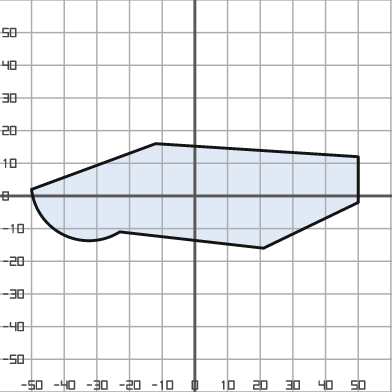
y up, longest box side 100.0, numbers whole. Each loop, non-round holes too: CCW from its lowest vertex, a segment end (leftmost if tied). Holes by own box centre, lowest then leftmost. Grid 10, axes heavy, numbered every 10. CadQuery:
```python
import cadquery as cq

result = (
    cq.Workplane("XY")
    .moveTo(21.0, -16.0)
    .lineTo(50.0, -2.0)
    .lineTo(50.0, 12.0)
    .lineTo(-12.0, 16.0)
    .lineTo(-50.0, 2.0)
    .threePointArc((-40.0, -12.0), (-23.0, -11.0))
    .close()
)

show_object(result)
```